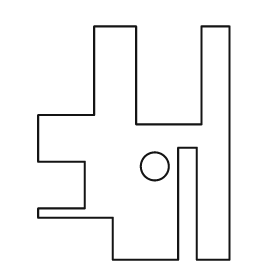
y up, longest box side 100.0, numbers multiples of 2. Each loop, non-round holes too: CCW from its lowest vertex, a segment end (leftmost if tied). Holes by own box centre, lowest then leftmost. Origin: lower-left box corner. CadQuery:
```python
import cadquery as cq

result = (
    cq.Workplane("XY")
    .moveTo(32.0, 0.0)
    .lineTo(60.0, 0.0)
    .lineTo(60.0, 48.0)
    .lineTo(68.0, 48.0)
    .lineTo(68.0, 0.0)
    .lineTo(82.0, 0.0)
    .lineTo(82.0, 100.0)
    .lineTo(70.0, 100.0)
    .lineTo(70.0, 58.0)
    .lineTo(42.0, 58.0)
    .lineTo(42.0, 100.0)
    .lineTo(24.0, 100.0)
    .lineTo(24.0, 62.0)
    .lineTo(0.0, 62.0)
    .lineTo(0.0, 42.0)
    .lineTo(20.0, 42.0)
    .lineTo(20.0, 22.0)
    .lineTo(0.0, 22.0)
    .lineTo(0.0, 18.0)
    .lineTo(32.0, 18.0)
    .close()
    .moveTo(50.0, 40.0)
    .circle(6.0)
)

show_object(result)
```